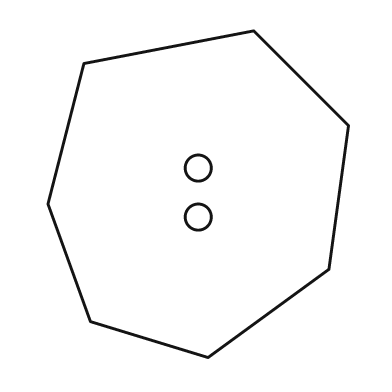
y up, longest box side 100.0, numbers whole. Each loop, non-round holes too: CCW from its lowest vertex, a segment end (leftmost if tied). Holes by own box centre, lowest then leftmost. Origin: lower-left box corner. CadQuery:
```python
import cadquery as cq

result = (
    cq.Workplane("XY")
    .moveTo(49.0, 0.0)
    .lineTo(86.0, 27.0)
    .lineTo(92.0, 71.0)
    .lineTo(63.0, 100.0)
    .lineTo(11.0, 90.0)
    .lineTo(0.0, 47.0)
    .lineTo(13.0, 11.0)
    .close()
    .moveTo(46.0, 43.0)
    .circle(4.0)
    .moveTo(46.0, 58.0)
    .circle(4.0)
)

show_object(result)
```